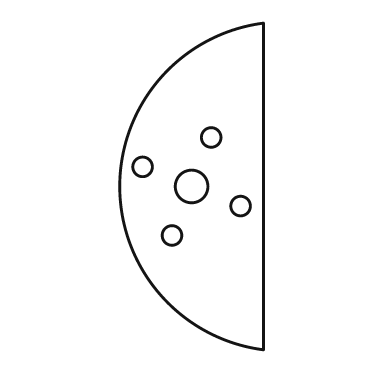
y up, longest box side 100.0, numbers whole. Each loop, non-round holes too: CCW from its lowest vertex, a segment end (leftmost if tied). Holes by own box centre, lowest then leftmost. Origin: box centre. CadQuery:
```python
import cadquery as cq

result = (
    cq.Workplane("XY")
    .moveTo(22.0, -50.0)
    .lineTo(22.0, 50.0)
    .threePointArc((-22.0, 0.0), (22.0, -50.0))
    .close()
    .moveTo(-6.0, -15.0)
    .circle(3.0)
    .moveTo(15.0, -6.0)
    .circle(3.0)
    .moveTo(0.0, 0.0)
    .circle(5.0)
    .moveTo(-15.0, 6.0)
    .circle(3.0)
    .moveTo(6.0, 15.0)
    .circle(3.0)
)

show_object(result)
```